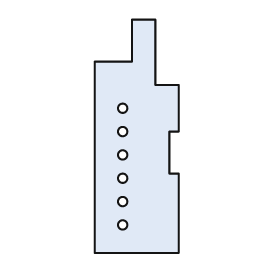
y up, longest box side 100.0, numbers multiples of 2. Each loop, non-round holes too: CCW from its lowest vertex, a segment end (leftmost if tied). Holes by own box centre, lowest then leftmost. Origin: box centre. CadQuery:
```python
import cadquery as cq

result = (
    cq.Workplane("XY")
    .moveTo(-18.0, -50.0)
    .lineTo(18.0, -50.0)
    .lineTo(18.0, -16.0)
    .lineTo(14.0, -16.0)
    .lineTo(14.0, 2.0)
    .lineTo(18.0, 2.0)
    .lineTo(18.0, 22.0)
    .lineTo(8.0, 22.0)
    .lineTo(8.0, 50.0)
    .lineTo(-2.0, 50.0)
    .lineTo(-2.0, 32.0)
    .lineTo(-18.0, 32.0)
    .close()
    .moveTo(-6.0, -38.0)
    .circle(2.0)
    .moveTo(-6.0, -28.0)
    .circle(2.0)
    .moveTo(-6.0, -18.0)
    .circle(2.0)
    .moveTo(-6.0, -8.0)
    .circle(2.0)
    .moveTo(-6.0, 2.0)
    .circle(2.0)
    .moveTo(-6.0, 12.0)
    .circle(2.0)
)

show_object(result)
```